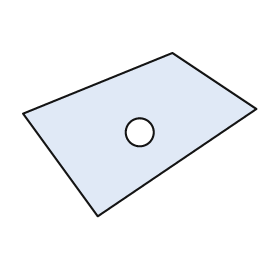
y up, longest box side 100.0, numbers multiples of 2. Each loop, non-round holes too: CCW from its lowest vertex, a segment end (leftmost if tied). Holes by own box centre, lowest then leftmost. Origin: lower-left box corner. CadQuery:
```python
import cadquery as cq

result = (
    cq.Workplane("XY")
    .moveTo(32.0, 0.0)
    .lineTo(100.0, 46.0)
    .lineTo(64.0, 70.0)
    .lineTo(0.0, 44.0)
    .close()
    .moveTo(50.0, 36.0)
    .circle(6.0)
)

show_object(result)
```